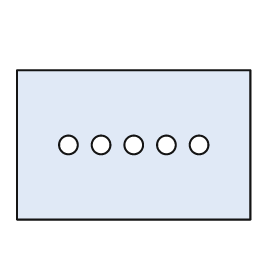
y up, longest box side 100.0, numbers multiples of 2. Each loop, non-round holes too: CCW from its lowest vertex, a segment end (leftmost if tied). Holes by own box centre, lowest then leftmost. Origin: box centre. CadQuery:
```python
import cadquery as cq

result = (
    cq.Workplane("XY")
    .moveTo(-50.0, -32.0)
    .lineTo(50.0, -32.0)
    .lineTo(50.0, 32.0)
    .lineTo(-50.0, 32.0)
    .close()
    .moveTo(-28.0, 0.0)
    .circle(4.0)
    .moveTo(-14.0, 0.0)
    .circle(4.0)
    .moveTo(0.0, 0.0)
    .circle(4.0)
    .moveTo(14.0, 0.0)
    .circle(4.0)
    .moveTo(28.0, 0.0)
    .circle(4.0)
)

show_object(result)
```